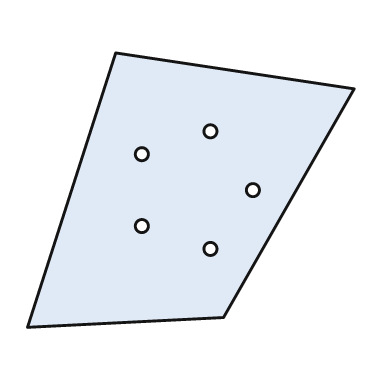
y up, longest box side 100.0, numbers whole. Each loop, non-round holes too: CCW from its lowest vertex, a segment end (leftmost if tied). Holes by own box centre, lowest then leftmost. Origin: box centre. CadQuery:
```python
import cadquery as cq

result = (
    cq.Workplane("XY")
    .moveTo(-50.0, -42.0)
    .lineTo(10.0, -39.0)
    .lineTo(50.0, 31.0)
    .lineTo(-23.0, 42.0)
    .close()
    .moveTo(6.0, -18.0)
    .circle(2.0)
    .moveTo(-15.0, -11.0)
    .circle(2.0)
    .moveTo(19.0, 0.0)
    .circle(2.0)
    .moveTo(-15.0, 11.0)
    .circle(2.0)
    .moveTo(6.0, 18.0)
    .circle(2.0)
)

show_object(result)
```